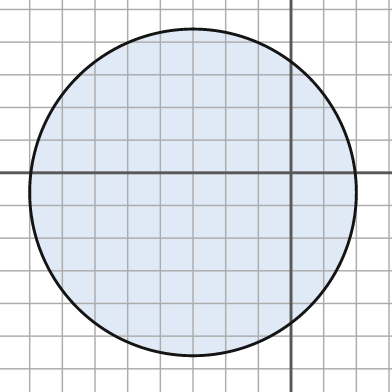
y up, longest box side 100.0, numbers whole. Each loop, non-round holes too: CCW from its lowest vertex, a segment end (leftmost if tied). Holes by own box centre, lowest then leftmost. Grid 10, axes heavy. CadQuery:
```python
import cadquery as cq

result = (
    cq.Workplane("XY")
    .moveTo(-30.0, -6.0)
    .circle(50.0)
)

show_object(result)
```